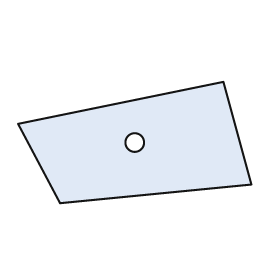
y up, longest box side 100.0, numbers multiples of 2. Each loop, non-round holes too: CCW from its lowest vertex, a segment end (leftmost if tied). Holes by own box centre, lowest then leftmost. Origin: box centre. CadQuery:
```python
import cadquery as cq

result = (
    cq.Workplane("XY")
    .moveTo(-32.0, -26.0)
    .lineTo(50.0, -18.0)
    .lineTo(38.0, 26.0)
    .lineTo(-50.0, 8.0)
    .close()
    .moveTo(0.0, 0.0)
    .circle(4.0)
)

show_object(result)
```